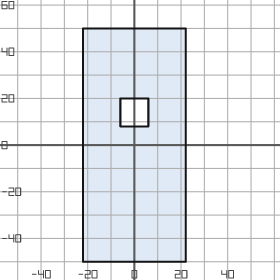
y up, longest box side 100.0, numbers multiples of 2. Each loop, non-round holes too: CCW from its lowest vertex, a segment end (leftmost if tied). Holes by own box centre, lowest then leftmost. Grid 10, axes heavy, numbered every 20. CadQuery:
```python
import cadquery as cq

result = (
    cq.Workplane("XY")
    .moveTo(-22.0, -50.0)
    .lineTo(22.0, -50.0)
    .lineTo(22.0, 50.0)
    .lineTo(-22.0, 50.0)
    .close()
    .moveTo(-6.0, 8.0)
    .lineTo(6.0, 8.0)
    .lineTo(6.0, 20.0)
    .lineTo(-6.0, 20.0)
    .close()
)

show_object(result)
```